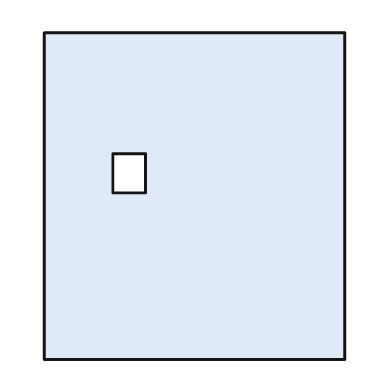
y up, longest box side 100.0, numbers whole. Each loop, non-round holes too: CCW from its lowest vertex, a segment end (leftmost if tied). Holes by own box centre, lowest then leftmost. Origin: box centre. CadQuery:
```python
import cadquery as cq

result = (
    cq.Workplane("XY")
    .moveTo(-46.0, -50.0)
    .lineTo(46.0, -50.0)
    .lineTo(46.0, 50.0)
    .lineTo(-46.0, 50.0)
    .close()
    .moveTo(-25.0, 1.0)
    .lineTo(-15.0, 1.0)
    .lineTo(-15.0, 13.0)
    .lineTo(-25.0, 13.0)
    .close()
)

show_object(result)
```